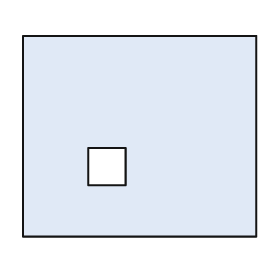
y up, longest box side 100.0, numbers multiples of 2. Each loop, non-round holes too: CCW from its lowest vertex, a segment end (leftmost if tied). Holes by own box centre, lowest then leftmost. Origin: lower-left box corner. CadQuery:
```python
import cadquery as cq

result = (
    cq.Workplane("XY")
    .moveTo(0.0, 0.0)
    .lineTo(100.0, 0.0)
    .lineTo(100.0, 86.0)
    .lineTo(0.0, 86.0)
    .close()
    .moveTo(28.0, 22.0)
    .lineTo(44.0, 22.0)
    .lineTo(44.0, 38.0)
    .lineTo(28.0, 38.0)
    .close()
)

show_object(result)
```